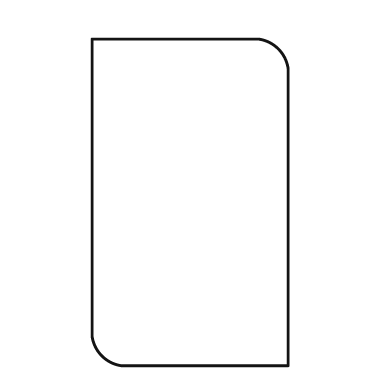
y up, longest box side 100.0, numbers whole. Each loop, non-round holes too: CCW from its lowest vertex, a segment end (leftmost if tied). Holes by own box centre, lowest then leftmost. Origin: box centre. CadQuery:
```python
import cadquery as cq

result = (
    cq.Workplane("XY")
    .moveTo(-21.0, -50.0)
    .lineTo(30.0, -50.0)
    .lineTo(30.0, 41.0)
    .threePointArc((27.0, 47.0), (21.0, 50.0))
    .lineTo(-30.0, 50.0)
    .lineTo(-30.0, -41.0)
    .threePointArc((-27.0, -47.0), (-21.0, -50.0))
    .close()
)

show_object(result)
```